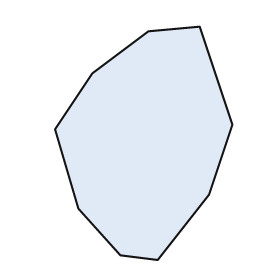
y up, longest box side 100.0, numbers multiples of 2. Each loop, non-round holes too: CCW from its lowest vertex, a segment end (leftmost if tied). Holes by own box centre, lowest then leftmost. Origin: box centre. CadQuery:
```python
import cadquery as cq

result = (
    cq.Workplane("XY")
    .moveTo(6.0, -50.0)
    .lineTo(28.0, -22.0)
    .lineTo(38.0, 8.0)
    .lineTo(24.0, 50.0)
    .lineTo(2.0, 48.0)
    .lineTo(-22.0, 30.0)
    .lineTo(-38.0, 6.0)
    .lineTo(-28.0, -28.0)
    .lineTo(-10.0, -48.0)
    .close()
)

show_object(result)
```